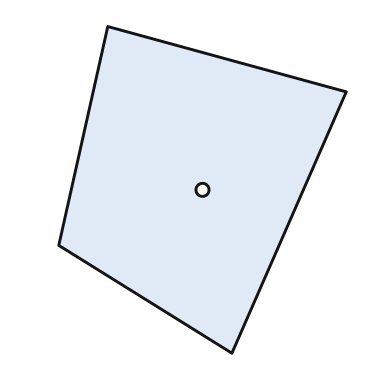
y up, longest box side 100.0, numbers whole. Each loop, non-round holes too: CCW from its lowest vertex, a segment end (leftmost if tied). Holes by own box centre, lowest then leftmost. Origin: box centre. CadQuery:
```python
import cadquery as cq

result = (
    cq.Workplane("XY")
    .moveTo(9.0, -50.0)
    .lineTo(44.0, 30.0)
    .lineTo(-29.0, 50.0)
    .lineTo(-44.0, -17.0)
    .close()
    .moveTo(0.0, 0.0)
    .circle(2.0)
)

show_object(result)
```